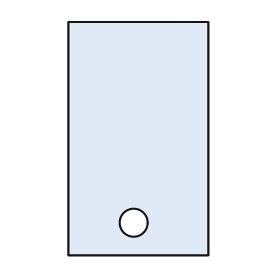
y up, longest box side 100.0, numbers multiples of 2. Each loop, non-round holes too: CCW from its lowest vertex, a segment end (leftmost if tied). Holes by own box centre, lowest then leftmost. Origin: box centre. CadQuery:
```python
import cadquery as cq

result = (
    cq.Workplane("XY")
    .moveTo(-30.0, -50.0)
    .lineTo(30.0, -50.0)
    .lineTo(30.0, 50.0)
    .lineTo(-30.0, 50.0)
    .close()
    .moveTo(-2.0, -36.0)
    .circle(6.0)
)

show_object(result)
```